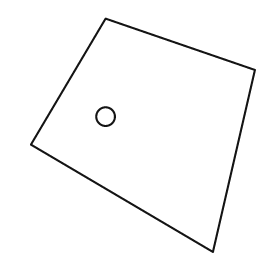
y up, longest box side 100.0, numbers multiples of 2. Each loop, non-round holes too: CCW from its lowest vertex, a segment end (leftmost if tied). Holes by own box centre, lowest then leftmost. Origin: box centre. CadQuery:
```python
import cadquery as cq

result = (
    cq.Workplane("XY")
    .moveTo(30.0, -50.0)
    .lineTo(48.0, 28.0)
    .lineTo(-16.0, 50.0)
    .lineTo(-48.0, -4.0)
    .close()
    .moveTo(-16.0, 8.0)
    .circle(4.0)
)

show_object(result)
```